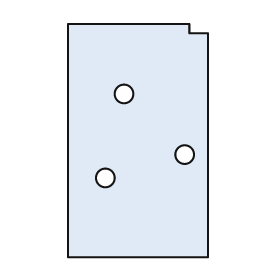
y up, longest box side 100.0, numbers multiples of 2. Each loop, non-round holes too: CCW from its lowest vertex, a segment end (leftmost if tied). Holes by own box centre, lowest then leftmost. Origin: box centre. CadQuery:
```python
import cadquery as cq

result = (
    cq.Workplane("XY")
    .moveTo(-30.0, -50.0)
    .lineTo(30.0, -50.0)
    .lineTo(30.0, 46.0)
    .lineTo(22.0, 46.0)
    .lineTo(22.0, 50.0)
    .lineTo(-30.0, 50.0)
    .close()
    .moveTo(-14.0, -16.0)
    .circle(4.0)
    .moveTo(20.0, -6.0)
    .circle(4.0)
    .moveTo(-6.0, 20.0)
    .circle(4.0)
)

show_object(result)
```